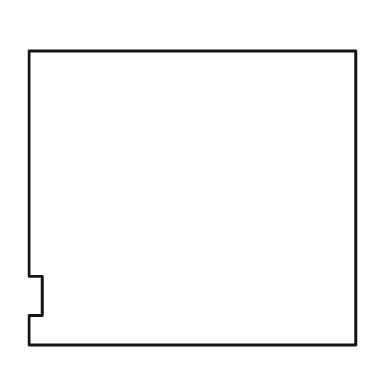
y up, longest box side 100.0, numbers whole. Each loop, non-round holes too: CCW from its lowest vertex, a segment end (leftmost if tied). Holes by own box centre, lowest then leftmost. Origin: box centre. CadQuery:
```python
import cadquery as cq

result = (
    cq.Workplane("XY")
    .moveTo(-50.0, -45.0)
    .lineTo(50.0, -45.0)
    .lineTo(50.0, 45.0)
    .lineTo(-50.0, 45.0)
    .lineTo(-50.0, -24.0)
    .lineTo(-46.0, -24.0)
    .lineTo(-46.0, -36.0)
    .lineTo(-50.0, -36.0)
    .close()
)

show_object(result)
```